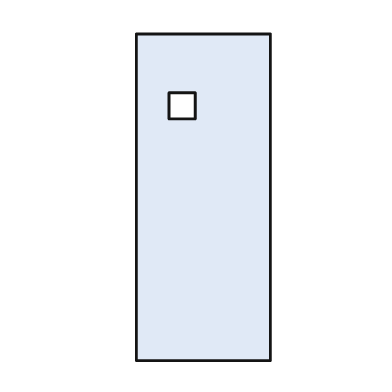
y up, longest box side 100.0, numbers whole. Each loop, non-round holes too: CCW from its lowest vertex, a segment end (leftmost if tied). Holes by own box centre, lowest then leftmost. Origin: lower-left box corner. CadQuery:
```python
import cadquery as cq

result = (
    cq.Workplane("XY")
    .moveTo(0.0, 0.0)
    .lineTo(41.0, 0.0)
    .lineTo(41.0, 100.0)
    .lineTo(0.0, 100.0)
    .close()
    .moveTo(10.0, 74.0)
    .lineTo(18.0, 74.0)
    .lineTo(18.0, 82.0)
    .lineTo(10.0, 82.0)
    .close()
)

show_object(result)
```